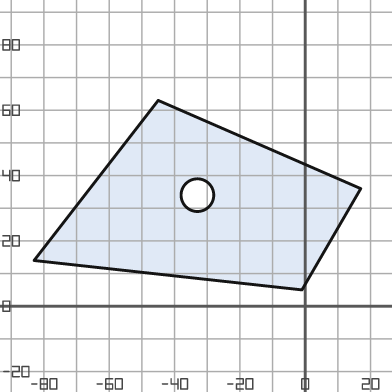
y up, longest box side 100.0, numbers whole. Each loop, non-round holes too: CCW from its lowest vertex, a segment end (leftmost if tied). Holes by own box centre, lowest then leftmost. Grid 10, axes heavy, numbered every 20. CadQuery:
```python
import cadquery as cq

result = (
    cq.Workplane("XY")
    .moveTo(-1.0, 5.0)
    .lineTo(17.0, 36.0)
    .lineTo(-45.0, 63.0)
    .lineTo(-83.0, 14.0)
    .close()
    .moveTo(-33.0, 34.0)
    .circle(5.0)
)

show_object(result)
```